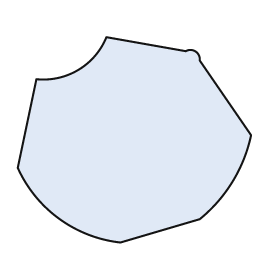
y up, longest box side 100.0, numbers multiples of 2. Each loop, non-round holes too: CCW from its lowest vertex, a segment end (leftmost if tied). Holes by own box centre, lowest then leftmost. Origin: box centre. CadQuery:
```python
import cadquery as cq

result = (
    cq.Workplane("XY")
    .moveTo(-6.0, -44.0)
    .lineTo(28.0, -34.0)
    .threePointArc((42.0, -18.0), (50.0, 2.0))
    .lineTo(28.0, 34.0)
    .threePointArc((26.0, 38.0), (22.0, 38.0))
    .lineTo(-12.0, 44.0)
    .threePointArc((-24.0, 30.0), (-42.0, 26.0))
    .lineTo(-50.0, -12.0)
    .threePointArc((-32.0, -34.0), (-6.0, -44.0))
    .close()
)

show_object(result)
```